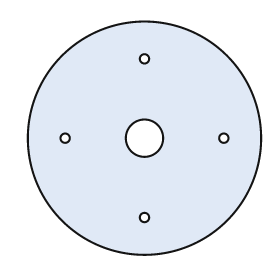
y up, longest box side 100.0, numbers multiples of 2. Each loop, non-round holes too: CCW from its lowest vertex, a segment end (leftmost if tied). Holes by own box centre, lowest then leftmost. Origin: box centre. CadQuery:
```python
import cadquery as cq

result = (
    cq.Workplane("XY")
    .moveTo(0.0, 0.0)
    .circle(50.0)
    .moveTo(0.0, -34.0)
    .circle(2.0)
    .moveTo(-34.0, 0.0)
    .circle(2.0)
    .moveTo(0.0, 0.0)
    .circle(8.0)
    .moveTo(34.0, 0.0)
    .circle(2.0)
    .moveTo(0.0, 34.0)
    .circle(2.0)
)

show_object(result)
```